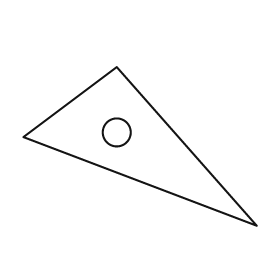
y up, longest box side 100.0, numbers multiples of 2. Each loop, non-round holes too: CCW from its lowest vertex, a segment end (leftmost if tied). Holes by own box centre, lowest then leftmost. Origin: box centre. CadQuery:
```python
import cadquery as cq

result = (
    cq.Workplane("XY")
    .moveTo(50.0, -34.0)
    .lineTo(-10.0, 34.0)
    .lineTo(-50.0, 4.0)
    .close()
    .moveTo(-10.0, 6.0)
    .circle(6.0)
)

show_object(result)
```